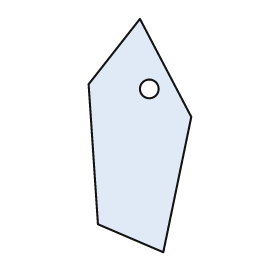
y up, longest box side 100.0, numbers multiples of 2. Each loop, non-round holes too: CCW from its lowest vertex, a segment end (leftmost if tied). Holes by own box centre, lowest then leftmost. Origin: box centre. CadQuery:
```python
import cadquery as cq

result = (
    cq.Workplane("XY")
    .moveTo(10.0, -50.0)
    .lineTo(22.0, 8.0)
    .lineTo(0.0, 50.0)
    .lineTo(-22.0, 22.0)
    .lineTo(-18.0, -38.0)
    .close()
    .moveTo(4.0, 20.0)
    .circle(4.0)
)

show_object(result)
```